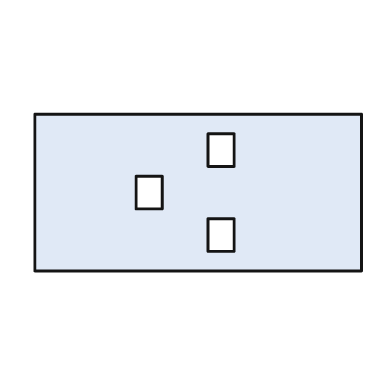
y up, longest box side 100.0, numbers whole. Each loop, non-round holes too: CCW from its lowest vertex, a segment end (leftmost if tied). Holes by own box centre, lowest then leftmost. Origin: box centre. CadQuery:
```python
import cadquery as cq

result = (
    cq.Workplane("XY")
    .moveTo(-50.0, -24.0)
    .lineTo(50.0, -24.0)
    .lineTo(50.0, 24.0)
    .lineTo(-50.0, 24.0)
    .close()
    .moveTo(3.0, -18.0)
    .lineTo(11.0, -18.0)
    .lineTo(11.0, -8.0)
    .lineTo(3.0, -8.0)
    .close()
    .moveTo(-19.0, -5.0)
    .lineTo(-11.0, -5.0)
    .lineTo(-11.0, 5.0)
    .lineTo(-19.0, 5.0)
    .close()
    .moveTo(3.0, 8.0)
    .lineTo(11.0, 8.0)
    .lineTo(11.0, 18.0)
    .lineTo(3.0, 18.0)
    .close()
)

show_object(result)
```